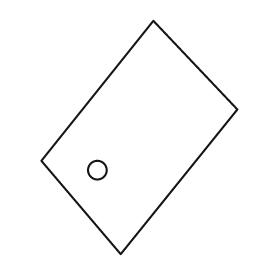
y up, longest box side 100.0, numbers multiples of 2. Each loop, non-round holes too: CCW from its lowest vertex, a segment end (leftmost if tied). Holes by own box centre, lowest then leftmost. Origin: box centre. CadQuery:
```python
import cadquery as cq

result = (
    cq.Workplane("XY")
    .moveTo(-8.0, -50.0)
    .lineTo(42.0, 12.0)
    .lineTo(6.0, 50.0)
    .lineTo(-42.0, -10.0)
    .close()
    .moveTo(-18.0, -14.0)
    .circle(4.0)
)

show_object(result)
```